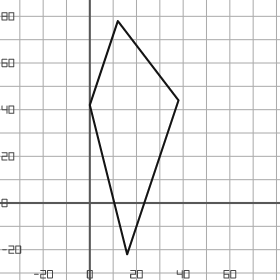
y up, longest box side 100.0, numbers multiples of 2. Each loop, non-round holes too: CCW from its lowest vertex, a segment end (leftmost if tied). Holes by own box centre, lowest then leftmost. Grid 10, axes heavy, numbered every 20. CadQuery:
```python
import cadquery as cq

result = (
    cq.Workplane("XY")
    .moveTo(16.0, -22.0)
    .lineTo(38.0, 44.0)
    .lineTo(12.0, 78.0)
    .lineTo(0.0, 42.0)
    .close()
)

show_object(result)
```